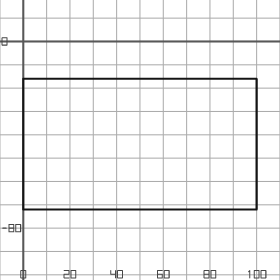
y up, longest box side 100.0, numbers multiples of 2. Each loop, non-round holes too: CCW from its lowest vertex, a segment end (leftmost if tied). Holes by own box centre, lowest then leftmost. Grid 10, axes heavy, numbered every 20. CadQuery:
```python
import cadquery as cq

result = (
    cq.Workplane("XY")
    .moveTo(0.0, -72.0)
    .lineTo(100.0, -72.0)
    .lineTo(100.0, -16.0)
    .lineTo(0.0, -16.0)
    .close()
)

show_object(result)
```